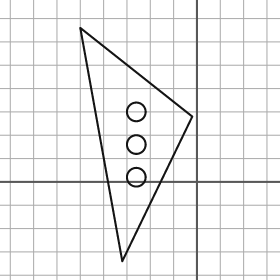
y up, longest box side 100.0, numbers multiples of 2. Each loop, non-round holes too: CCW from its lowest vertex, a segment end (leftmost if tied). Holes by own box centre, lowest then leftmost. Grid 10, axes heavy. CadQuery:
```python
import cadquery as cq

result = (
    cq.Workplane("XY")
    .moveTo(-32.0, -34.0)
    .lineTo(-2.0, 28.0)
    .lineTo(-50.0, 66.0)
    .close()
    .moveTo(-26.0, 2.0)
    .circle(4.0)
    .moveTo(-26.0, 16.0)
    .circle(4.0)
    .moveTo(-26.0, 30.0)
    .circle(4.0)
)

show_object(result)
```